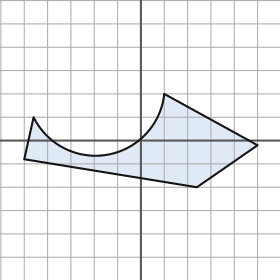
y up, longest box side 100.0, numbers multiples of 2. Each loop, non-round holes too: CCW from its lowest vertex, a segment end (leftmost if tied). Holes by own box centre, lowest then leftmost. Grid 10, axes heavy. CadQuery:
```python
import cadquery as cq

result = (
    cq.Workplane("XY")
    .moveTo(24.0, -20.0)
    .lineTo(50.0, -2.0)
    .lineTo(10.0, 20.0)
    .threePointArc((-14.0, -6.0), (-46.0, 10.0))
    .lineTo(-50.0, -8.0)
    .close()
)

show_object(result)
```